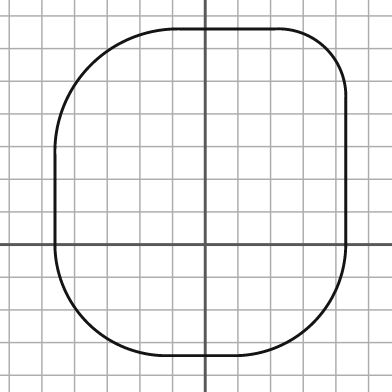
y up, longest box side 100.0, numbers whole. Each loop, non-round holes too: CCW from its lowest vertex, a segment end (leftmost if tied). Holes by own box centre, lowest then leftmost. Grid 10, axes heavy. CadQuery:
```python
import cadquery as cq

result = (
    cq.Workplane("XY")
    .moveTo(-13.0, -34.0)
    .lineTo(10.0, -34.0)
    .threePointArc((33.0, -24.0), (43.0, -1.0))
    .lineTo(43.0, 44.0)
    .threePointArc((37.0, 60.0), (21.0, 66.0))
    .lineTo(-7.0, 66.0)
    .threePointArc((-35.0, 55.0), (-46.0, 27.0))
    .lineTo(-46.0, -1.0)
    .threePointArc((-36.0, -24.0), (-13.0, -34.0))
    .close()
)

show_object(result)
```